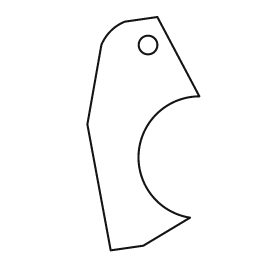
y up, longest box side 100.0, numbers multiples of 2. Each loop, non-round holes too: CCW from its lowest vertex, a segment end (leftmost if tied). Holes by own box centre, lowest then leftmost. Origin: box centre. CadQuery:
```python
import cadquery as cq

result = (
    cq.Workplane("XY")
    .moveTo(-14.0, -50.0)
    .lineTo(0.0, -48.0)
    .lineTo(20.0, -36.0)
    .threePointArc((-2.0, -8.0), (24.0, 16.0))
    .lineTo(6.0, 50.0)
    .lineTo(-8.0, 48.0)
    .threePointArc((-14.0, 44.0), (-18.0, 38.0))
    .lineTo(-24.0, 4.0)
    .close()
    .moveTo(2.0, 38.0)
    .circle(4.0)
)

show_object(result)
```